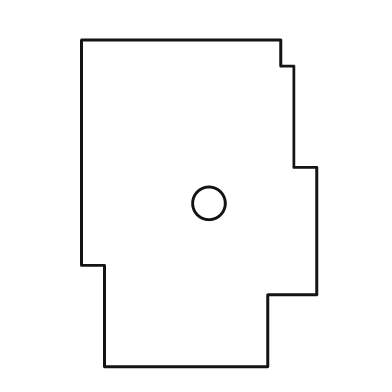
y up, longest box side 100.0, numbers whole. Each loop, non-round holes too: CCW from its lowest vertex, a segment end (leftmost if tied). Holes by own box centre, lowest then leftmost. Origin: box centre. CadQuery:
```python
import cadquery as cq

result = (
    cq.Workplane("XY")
    .moveTo(-29.0, -50.0)
    .lineTo(21.0, -50.0)
    .lineTo(21.0, -28.0)
    .lineTo(36.0, -28.0)
    .lineTo(36.0, 11.0)
    .lineTo(29.0, 11.0)
    .lineTo(29.0, 42.0)
    .lineTo(25.0, 42.0)
    .lineTo(25.0, 50.0)
    .lineTo(-36.0, 50.0)
    .lineTo(-36.0, -19.0)
    .lineTo(-29.0, -19.0)
    .close()
    .moveTo(3.0, 0.0)
    .circle(5.0)
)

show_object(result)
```